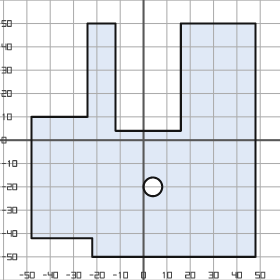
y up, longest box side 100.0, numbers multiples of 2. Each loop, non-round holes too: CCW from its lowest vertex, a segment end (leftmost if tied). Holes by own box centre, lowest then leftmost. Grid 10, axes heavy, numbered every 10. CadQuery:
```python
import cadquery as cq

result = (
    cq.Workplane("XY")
    .moveTo(-22.0, -50.0)
    .lineTo(48.0, -50.0)
    .lineTo(48.0, 50.0)
    .lineTo(16.0, 50.0)
    .lineTo(16.0, 4.0)
    .lineTo(-12.0, 4.0)
    .lineTo(-12.0, 50.0)
    .lineTo(-24.0, 50.0)
    .lineTo(-24.0, 10.0)
    .lineTo(-48.0, 10.0)
    .lineTo(-48.0, -42.0)
    .lineTo(-22.0, -42.0)
    .close()
    .moveTo(4.0, -20.0)
    .circle(4.0)
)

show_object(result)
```